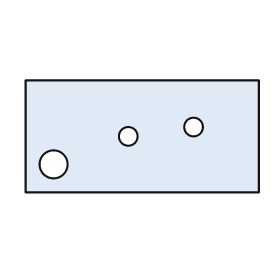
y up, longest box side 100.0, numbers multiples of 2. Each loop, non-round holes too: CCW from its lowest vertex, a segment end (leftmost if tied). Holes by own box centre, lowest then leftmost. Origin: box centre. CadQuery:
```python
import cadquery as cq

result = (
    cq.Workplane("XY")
    .moveTo(-50.0, -24.0)
    .lineTo(50.0, -24.0)
    .lineTo(50.0, 24.0)
    .lineTo(-50.0, 24.0)
    .close()
    .moveTo(-38.0, -12.0)
    .circle(6.0)
    .moveTo(-6.0, 0.0)
    .circle(4.0)
    .moveTo(22.0, 4.0)
    .circle(4.0)
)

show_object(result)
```